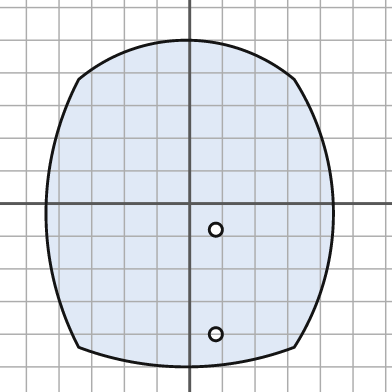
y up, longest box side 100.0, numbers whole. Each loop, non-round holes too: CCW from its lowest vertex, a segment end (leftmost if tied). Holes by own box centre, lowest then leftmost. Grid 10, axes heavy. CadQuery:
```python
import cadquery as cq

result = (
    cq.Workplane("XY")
    .moveTo(-34.0, -44.0)
    .threePointArc((-1.0, -50.0), (32.0, -44.0))
    .threePointArc((44.0, -3.0), (32.0, 38.0))
    .threePointArc((-1.0, 50.0), (-34.0, 38.0))
    .threePointArc((-44.0, -3.0), (-34.0, -44.0))
    .close()
    .moveTo(8.0, -40.0)
    .circle(2.0)
    .moveTo(8.0, -8.0)
    .circle(2.0)
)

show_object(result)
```